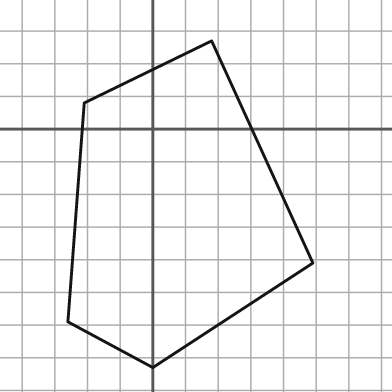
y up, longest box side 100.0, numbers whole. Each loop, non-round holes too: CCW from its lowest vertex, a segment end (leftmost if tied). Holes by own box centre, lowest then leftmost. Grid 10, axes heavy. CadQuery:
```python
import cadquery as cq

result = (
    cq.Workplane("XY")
    .moveTo(0.0, -73.0)
    .lineTo(49.0, -41.0)
    .lineTo(18.0, 27.0)
    .lineTo(-21.0, 8.0)
    .lineTo(-26.0, -59.0)
    .close()
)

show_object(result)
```